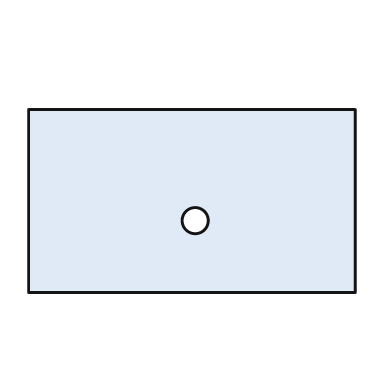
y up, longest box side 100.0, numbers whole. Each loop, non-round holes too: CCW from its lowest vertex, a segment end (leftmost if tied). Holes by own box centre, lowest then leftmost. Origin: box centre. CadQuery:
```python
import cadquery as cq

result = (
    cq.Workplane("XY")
    .moveTo(-50.0, -28.0)
    .lineTo(50.0, -28.0)
    .lineTo(50.0, 28.0)
    .lineTo(-50.0, 28.0)
    .close()
    .moveTo(1.0, -6.0)
    .circle(4.0)
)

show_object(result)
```